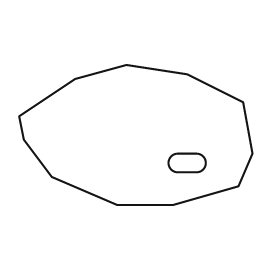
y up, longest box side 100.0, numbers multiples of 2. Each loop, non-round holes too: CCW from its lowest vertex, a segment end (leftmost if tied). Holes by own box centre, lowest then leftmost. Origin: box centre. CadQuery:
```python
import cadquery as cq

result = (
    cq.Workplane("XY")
    .moveTo(-8.0, -30.0)
    .lineTo(16.0, -30.0)
    .lineTo(44.0, -22.0)
    .lineTo(50.0, -8.0)
    .lineTo(46.0, 14.0)
    .lineTo(22.0, 26.0)
    .lineTo(-4.0, 30.0)
    .lineTo(-26.0, 24.0)
    .lineTo(-50.0, 8.0)
    .lineTo(-48.0, -2.0)
    .lineTo(-36.0, -18.0)
    .close()
    .moveTo(18.0, -16.0)
    .lineTo(26.0, -16.0)
    .threePointArc((30.0, -12.0), (26.0, -8.0))
    .lineTo(18.0, -8.0)
    .threePointArc((14.0, -12.0), (18.0, -16.0))
    .close()
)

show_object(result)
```